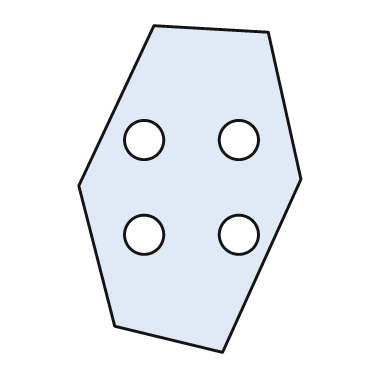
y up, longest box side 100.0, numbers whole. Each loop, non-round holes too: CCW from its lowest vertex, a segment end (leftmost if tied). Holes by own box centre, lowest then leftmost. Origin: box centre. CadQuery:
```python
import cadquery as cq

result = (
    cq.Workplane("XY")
    .moveTo(10.0, -50.0)
    .lineTo(34.0, 3.0)
    .lineTo(24.0, 48.0)
    .lineTo(-11.0, 50.0)
    .lineTo(-34.0, 1.0)
    .lineTo(-23.0, -42.0)
    .close()
    .moveTo(-14.0, -14.0)
    .circle(6.0)
    .moveTo(15.0, -14.0)
    .circle(6.0)
    .moveTo(-14.0, 15.0)
    .circle(6.0)
    .moveTo(15.0, 15.0)
    .circle(6.0)
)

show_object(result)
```